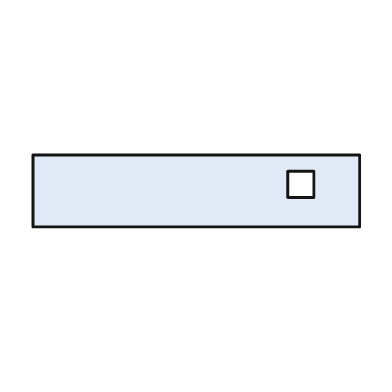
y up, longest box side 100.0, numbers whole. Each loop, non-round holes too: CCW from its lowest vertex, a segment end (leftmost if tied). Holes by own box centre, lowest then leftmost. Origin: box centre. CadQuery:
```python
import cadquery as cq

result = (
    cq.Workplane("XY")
    .moveTo(-50.0, -11.0)
    .lineTo(50.0, -11.0)
    .lineTo(50.0, 11.0)
    .lineTo(-50.0, 11.0)
    .close()
    .moveTo(28.0, -2.0)
    .lineTo(36.0, -2.0)
    .lineTo(36.0, 6.0)
    .lineTo(28.0, 6.0)
    .close()
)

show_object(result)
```